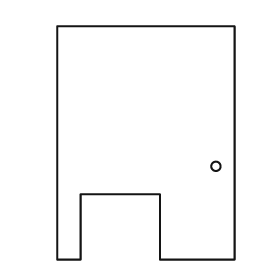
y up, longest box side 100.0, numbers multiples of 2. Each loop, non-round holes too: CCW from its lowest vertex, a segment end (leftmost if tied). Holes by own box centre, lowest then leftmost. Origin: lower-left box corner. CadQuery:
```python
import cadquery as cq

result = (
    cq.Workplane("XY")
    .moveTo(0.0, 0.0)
    .lineTo(10.0, 0.0)
    .lineTo(10.0, 28.0)
    .lineTo(44.0, 28.0)
    .lineTo(44.0, 0.0)
    .lineTo(76.0, 0.0)
    .lineTo(76.0, 100.0)
    .lineTo(0.0, 100.0)
    .close()
    .moveTo(68.0, 40.0)
    .circle(2.0)
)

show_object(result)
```